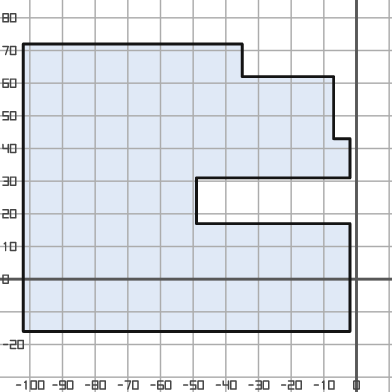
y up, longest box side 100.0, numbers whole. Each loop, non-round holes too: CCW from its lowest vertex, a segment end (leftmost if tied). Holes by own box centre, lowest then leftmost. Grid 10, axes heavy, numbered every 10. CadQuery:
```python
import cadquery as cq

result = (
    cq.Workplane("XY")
    .moveTo(-102.0, -16.0)
    .lineTo(-2.0, -16.0)
    .lineTo(-2.0, 17.0)
    .lineTo(-49.0, 17.0)
    .lineTo(-49.0, 31.0)
    .lineTo(-2.0, 31.0)
    .lineTo(-2.0, 43.0)
    .lineTo(-7.0, 43.0)
    .lineTo(-7.0, 62.0)
    .lineTo(-35.0, 62.0)
    .lineTo(-35.0, 72.0)
    .lineTo(-102.0, 72.0)
    .close()
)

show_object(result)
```